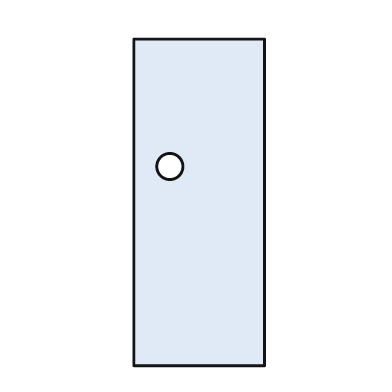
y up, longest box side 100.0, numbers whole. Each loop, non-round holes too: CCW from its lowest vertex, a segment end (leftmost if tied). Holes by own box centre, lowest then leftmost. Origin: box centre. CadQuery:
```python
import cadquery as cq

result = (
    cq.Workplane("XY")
    .moveTo(-20.0, -50.0)
    .lineTo(20.0, -50.0)
    .lineTo(20.0, 50.0)
    .lineTo(-20.0, 50.0)
    .close()
    .moveTo(-9.0, 11.0)
    .circle(4.0)
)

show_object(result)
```